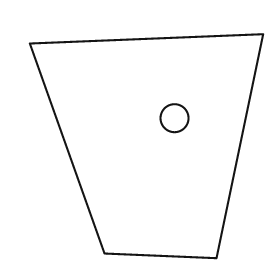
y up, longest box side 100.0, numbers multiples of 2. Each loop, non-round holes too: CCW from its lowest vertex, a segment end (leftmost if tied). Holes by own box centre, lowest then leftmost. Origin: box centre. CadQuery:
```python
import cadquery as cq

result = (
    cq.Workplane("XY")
    .moveTo(30.0, -48.0)
    .lineTo(50.0, 48.0)
    .lineTo(-50.0, 44.0)
    .lineTo(-18.0, -46.0)
    .close()
    .moveTo(12.0, 12.0)
    .circle(6.0)
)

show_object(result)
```